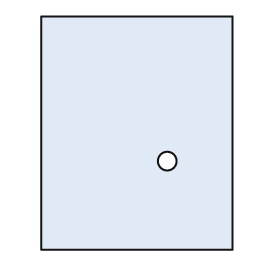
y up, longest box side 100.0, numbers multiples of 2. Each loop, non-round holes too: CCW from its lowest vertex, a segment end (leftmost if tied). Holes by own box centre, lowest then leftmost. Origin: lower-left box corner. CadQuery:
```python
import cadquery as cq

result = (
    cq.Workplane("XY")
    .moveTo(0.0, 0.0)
    .lineTo(82.0, 0.0)
    .lineTo(82.0, 100.0)
    .lineTo(0.0, 100.0)
    .close()
    .moveTo(54.0, 38.0)
    .circle(4.0)
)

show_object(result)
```